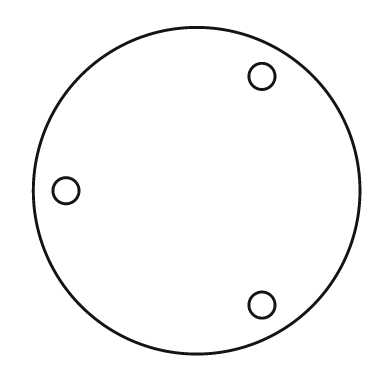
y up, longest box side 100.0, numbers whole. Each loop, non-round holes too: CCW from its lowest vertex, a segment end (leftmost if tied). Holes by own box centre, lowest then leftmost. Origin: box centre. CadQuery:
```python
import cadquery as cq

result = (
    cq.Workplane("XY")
    .moveTo(0.0, 0.0)
    .circle(50.0)
    .moveTo(20.0, -35.0)
    .circle(4.0)
    .moveTo(-40.0, 0.0)
    .circle(4.0)
    .moveTo(20.0, 35.0)
    .circle(4.0)
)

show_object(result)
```